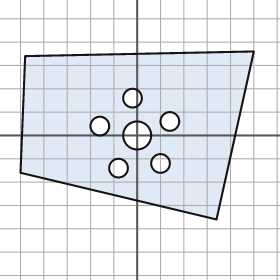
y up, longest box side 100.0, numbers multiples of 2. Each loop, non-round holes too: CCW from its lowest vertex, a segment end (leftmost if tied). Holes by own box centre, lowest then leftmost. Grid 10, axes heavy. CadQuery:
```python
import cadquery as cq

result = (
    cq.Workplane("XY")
    .moveTo(34.0, -36.0)
    .lineTo(50.0, 36.0)
    .lineTo(-48.0, 34.0)
    .lineTo(-50.0, -16.0)
    .close()
    .moveTo(-8.0, -14.0)
    .circle(4.0)
    .moveTo(10.0, -12.0)
    .circle(4.0)
    .moveTo(0.0, 0.0)
    .circle(6.0)
    .moveTo(-16.0, 4.0)
    .circle(4.0)
    .moveTo(14.0, 6.0)
    .circle(4.0)
    .moveTo(-2.0, 16.0)
    .circle(4.0)
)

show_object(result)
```